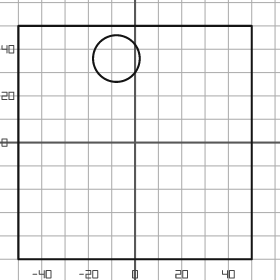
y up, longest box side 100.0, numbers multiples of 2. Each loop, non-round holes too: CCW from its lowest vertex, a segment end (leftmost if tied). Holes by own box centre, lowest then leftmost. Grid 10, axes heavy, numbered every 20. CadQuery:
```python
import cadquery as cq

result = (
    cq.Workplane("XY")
    .moveTo(-50.0, -50.0)
    .lineTo(50.0, -50.0)
    .lineTo(50.0, 50.0)
    .lineTo(-50.0, 50.0)
    .close()
    .moveTo(-8.0, 36.0)
    .circle(10.0)
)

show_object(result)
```